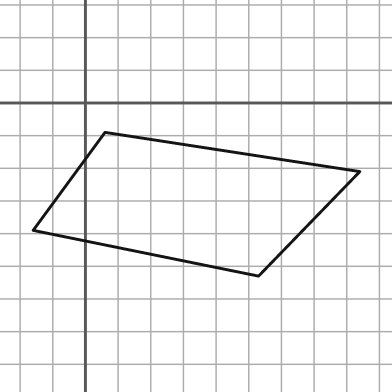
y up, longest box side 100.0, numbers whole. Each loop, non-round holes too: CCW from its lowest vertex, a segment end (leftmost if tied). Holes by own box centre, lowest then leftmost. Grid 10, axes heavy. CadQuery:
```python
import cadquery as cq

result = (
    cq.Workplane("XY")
    .moveTo(53.0, -53.0)
    .lineTo(84.0, -21.0)
    .lineTo(6.0, -9.0)
    .lineTo(-16.0, -39.0)
    .close()
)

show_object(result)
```